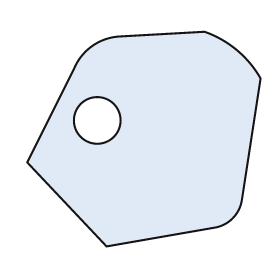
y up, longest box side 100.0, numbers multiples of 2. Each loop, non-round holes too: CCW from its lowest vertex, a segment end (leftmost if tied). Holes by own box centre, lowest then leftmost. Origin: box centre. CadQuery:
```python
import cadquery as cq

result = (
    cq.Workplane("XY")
    .moveTo(-16.0, -46.0)
    .lineTo(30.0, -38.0)
    .threePointArc((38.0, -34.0), (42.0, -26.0))
    .lineTo(50.0, 26.0)
    .threePointArc((40.0, 38.0), (26.0, 46.0))
    .lineTo(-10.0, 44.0)
    .threePointArc((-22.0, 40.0), (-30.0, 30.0))
    .lineTo(-50.0, -10.0)
    .close()
    .moveTo(-20.0, 8.0)
    .circle(10.0)
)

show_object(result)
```